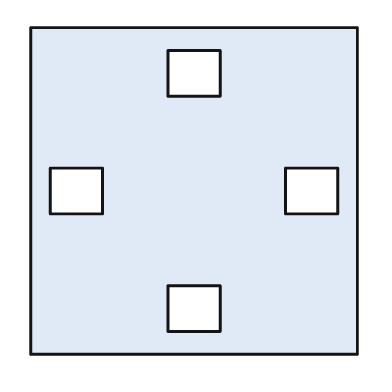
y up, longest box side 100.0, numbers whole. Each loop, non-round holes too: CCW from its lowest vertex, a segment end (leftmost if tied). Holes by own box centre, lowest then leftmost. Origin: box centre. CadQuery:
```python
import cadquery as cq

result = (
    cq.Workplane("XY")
    .moveTo(-50.0, -50.0)
    .lineTo(50.0, -50.0)
    .lineTo(50.0, 50.0)
    .lineTo(-50.0, 50.0)
    .close()
    .moveTo(-8.0, -43.0)
    .lineTo(8.0, -43.0)
    .lineTo(8.0, -29.0)
    .lineTo(-8.0, -29.0)
    .close()
    .moveTo(-44.0, -7.0)
    .lineTo(-28.0, -7.0)
    .lineTo(-28.0, 7.0)
    .lineTo(-44.0, 7.0)
    .close()
    .moveTo(28.0, -7.0)
    .lineTo(44.0, -7.0)
    .lineTo(44.0, 7.0)
    .lineTo(28.0, 7.0)
    .close()
    .moveTo(-8.0, 29.0)
    .lineTo(8.0, 29.0)
    .lineTo(8.0, 43.0)
    .lineTo(-8.0, 43.0)
    .close()
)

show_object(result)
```